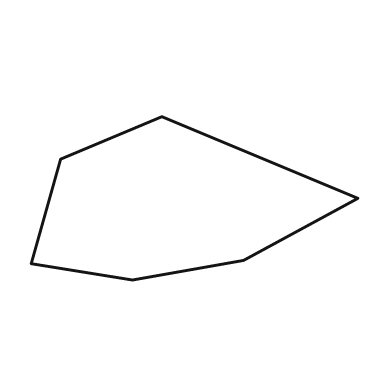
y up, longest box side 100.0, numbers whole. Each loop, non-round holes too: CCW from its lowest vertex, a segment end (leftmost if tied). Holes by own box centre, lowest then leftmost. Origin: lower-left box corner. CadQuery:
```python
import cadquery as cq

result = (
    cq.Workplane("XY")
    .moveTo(31.0, 0.0)
    .lineTo(65.0, 6.0)
    .lineTo(100.0, 25.0)
    .lineTo(40.0, 50.0)
    .lineTo(9.0, 37.0)
    .lineTo(0.0, 5.0)
    .close()
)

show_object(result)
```